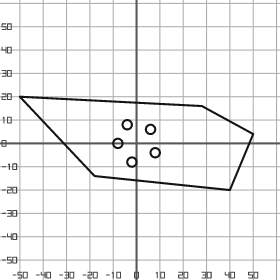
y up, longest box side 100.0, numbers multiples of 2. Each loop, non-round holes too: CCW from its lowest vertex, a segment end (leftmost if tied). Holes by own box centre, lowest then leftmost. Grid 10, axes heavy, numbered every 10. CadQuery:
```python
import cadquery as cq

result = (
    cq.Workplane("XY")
    .moveTo(40.0, -20.0)
    .lineTo(50.0, 4.0)
    .lineTo(28.0, 16.0)
    .lineTo(-50.0, 20.0)
    .lineTo(-18.0, -14.0)
    .close()
    .moveTo(-2.0, -8.0)
    .circle(2.0)
    .moveTo(8.0, -4.0)
    .circle(2.0)
    .moveTo(-8.0, 0.0)
    .circle(2.0)
    .moveTo(6.0, 6.0)
    .circle(2.0)
    .moveTo(-4.0, 8.0)
    .circle(2.0)
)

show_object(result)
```